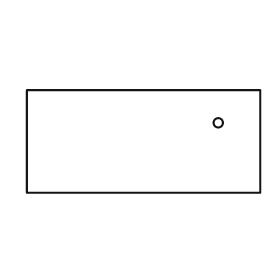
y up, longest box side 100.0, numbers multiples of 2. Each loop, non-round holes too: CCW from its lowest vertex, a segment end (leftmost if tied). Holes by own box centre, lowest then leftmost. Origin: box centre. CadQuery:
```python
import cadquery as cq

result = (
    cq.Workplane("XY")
    .moveTo(-50.0, -22.0)
    .lineTo(50.0, -22.0)
    .lineTo(50.0, 22.0)
    .lineTo(-50.0, 22.0)
    .close()
    .moveTo(32.0, 8.0)
    .circle(2.0)
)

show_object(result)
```